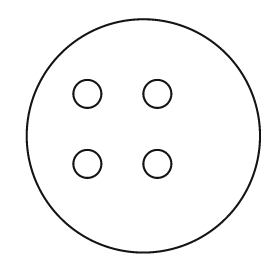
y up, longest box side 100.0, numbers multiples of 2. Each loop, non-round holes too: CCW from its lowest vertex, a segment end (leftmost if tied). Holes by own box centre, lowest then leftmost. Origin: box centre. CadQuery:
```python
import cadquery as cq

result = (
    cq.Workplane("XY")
    .moveTo(0.0, 0.0)
    .circle(50.0)
    .moveTo(-24.0, -12.0)
    .circle(6.0)
    .moveTo(6.0, -12.0)
    .circle(6.0)
    .moveTo(-24.0, 18.0)
    .circle(6.0)
    .moveTo(6.0, 18.0)
    .circle(6.0)
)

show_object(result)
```